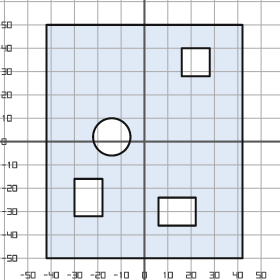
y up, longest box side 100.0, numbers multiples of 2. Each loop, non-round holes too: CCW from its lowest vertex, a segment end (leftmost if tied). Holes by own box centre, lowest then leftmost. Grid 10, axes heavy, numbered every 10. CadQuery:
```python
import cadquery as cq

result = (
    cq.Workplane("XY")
    .moveTo(-42.0, -50.0)
    .lineTo(42.0, -50.0)
    .lineTo(42.0, 50.0)
    .lineTo(-42.0, 50.0)
    .close()
    .moveTo(6.0, -36.0)
    .lineTo(22.0, -36.0)
    .lineTo(22.0, -24.0)
    .lineTo(6.0, -24.0)
    .close()
    .moveTo(-30.0, -32.0)
    .lineTo(-18.0, -32.0)
    .lineTo(-18.0, -16.0)
    .lineTo(-30.0, -16.0)
    .close()
    .moveTo(-14.0, 2.0)
    .circle(8.0)
    .moveTo(16.0, 28.0)
    .lineTo(28.0, 28.0)
    .lineTo(28.0, 40.0)
    .lineTo(16.0, 40.0)
    .close()
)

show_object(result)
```